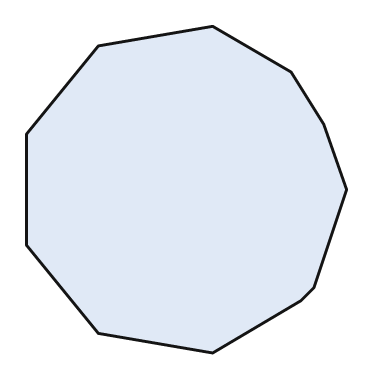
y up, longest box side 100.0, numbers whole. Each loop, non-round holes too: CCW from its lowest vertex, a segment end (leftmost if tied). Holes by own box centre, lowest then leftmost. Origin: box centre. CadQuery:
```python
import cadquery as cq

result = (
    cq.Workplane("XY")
    .moveTo(8.0, -50.0)
    .lineTo(35.0, -34.0)
    .lineTo(39.0, -30.0)
    .lineTo(49.0, 0.0)
    .lineTo(42.0, 20.0)
    .lineTo(32.0, 36.0)
    .lineTo(8.0, 50.0)
    .lineTo(-27.0, 44.0)
    .lineTo(-49.0, 17.0)
    .lineTo(-49.0, -17.0)
    .lineTo(-27.0, -44.0)
    .close()
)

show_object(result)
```